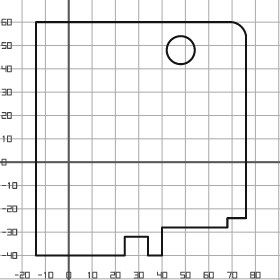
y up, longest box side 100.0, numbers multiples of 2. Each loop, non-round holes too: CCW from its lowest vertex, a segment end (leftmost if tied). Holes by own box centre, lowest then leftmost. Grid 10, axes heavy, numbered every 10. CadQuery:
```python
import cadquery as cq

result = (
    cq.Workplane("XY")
    .moveTo(-14.0, -40.0)
    .lineTo(24.0, -40.0)
    .lineTo(24.0, -32.0)
    .lineTo(34.0, -32.0)
    .lineTo(34.0, -40.0)
    .lineTo(40.0, -40.0)
    .lineTo(40.0, -28.0)
    .lineTo(68.0, -28.0)
    .lineTo(68.0, -24.0)
    .lineTo(76.0, -24.0)
    .lineTo(76.0, 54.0)
    .threePointArc((74.0, 58.0), (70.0, 60.0))
    .lineTo(-14.0, 60.0)
    .close()
    .moveTo(48.0, 48.0)
    .circle(6.0)
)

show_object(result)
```